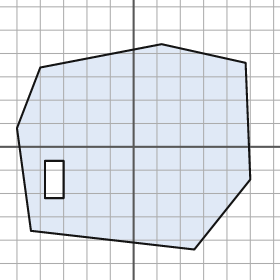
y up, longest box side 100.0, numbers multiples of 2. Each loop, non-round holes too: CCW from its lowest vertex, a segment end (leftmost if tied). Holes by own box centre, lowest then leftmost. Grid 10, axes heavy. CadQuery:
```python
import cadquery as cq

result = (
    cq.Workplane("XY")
    .moveTo(26.0, -44.0)
    .lineTo(50.0, -14.0)
    .lineTo(48.0, 36.0)
    .lineTo(12.0, 44.0)
    .lineTo(-40.0, 34.0)
    .lineTo(-50.0, 8.0)
    .lineTo(-44.0, -36.0)
    .close()
    .moveTo(-38.0, -22.0)
    .lineTo(-30.0, -22.0)
    .lineTo(-30.0, -6.0)
    .lineTo(-38.0, -6.0)
    .close()
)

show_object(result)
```